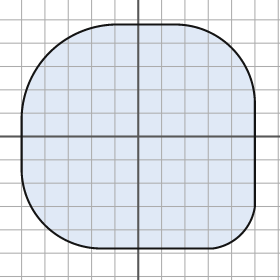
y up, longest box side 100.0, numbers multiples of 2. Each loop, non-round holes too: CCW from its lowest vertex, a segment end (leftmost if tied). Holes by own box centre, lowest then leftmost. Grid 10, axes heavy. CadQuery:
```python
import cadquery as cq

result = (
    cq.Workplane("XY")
    .moveTo(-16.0, -48.0)
    .lineTo(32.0, -48.0)
    .threePointArc((44.0, -42.0), (50.0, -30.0))
    .lineTo(50.0, 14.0)
    .threePointArc((40.0, 38.0), (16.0, 48.0))
    .lineTo(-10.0, 48.0)
    .threePointArc((-38.0, 36.0), (-50.0, 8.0))
    .lineTo(-50.0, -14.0)
    .threePointArc((-40.0, -38.0), (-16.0, -48.0))
    .close()
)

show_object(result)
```